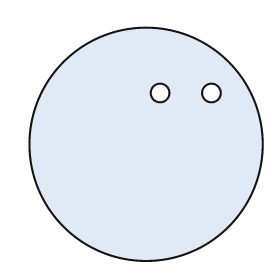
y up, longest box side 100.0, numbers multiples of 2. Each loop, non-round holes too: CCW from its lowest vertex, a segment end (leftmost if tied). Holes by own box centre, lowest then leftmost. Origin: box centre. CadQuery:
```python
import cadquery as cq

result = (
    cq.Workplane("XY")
    .moveTo(0.0, 0.0)
    .circle(50.0)
    .moveTo(6.0, 22.0)
    .circle(4.0)
    .moveTo(28.0, 22.0)
    .circle(4.0)
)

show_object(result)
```